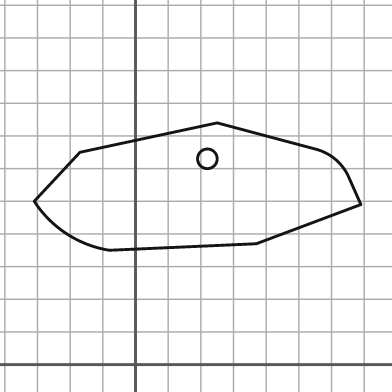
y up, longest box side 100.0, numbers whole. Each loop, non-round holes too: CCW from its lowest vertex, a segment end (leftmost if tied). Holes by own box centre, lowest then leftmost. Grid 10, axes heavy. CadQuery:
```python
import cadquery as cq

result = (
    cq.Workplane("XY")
    .moveTo(-8.0, 35.0)
    .lineTo(37.0, 37.0)
    .lineTo(69.0, 49.0)
    .lineTo(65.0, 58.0)
    .threePointArc((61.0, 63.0), (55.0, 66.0))
    .lineTo(25.0, 74.0)
    .lineTo(-17.0, 65.0)
    .lineTo(-31.0, 50.0)
    .threePointArc((-21.0, 40.0), (-8.0, 35.0))
    .close()
    .moveTo(22.0, 63.0)
    .circle(3.0)
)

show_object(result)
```